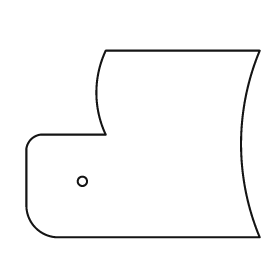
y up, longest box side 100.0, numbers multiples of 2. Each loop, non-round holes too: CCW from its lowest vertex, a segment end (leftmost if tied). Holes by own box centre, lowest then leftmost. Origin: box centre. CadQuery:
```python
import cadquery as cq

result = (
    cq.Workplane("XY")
    .moveTo(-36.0, -40.0)
    .lineTo(50.0, -40.0)
    .threePointArc((42.0, 0.0), (50.0, 40.0))
    .lineTo(-16.0, 40.0)
    .threePointArc((-20.0, 22.0), (-16.0, 4.0))
    .lineTo(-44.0, 4.0)
    .threePointArc((-48.0, 2.0), (-50.0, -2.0))
    .lineTo(-50.0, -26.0)
    .threePointArc((-46.0, -36.0), (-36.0, -40.0))
    .close()
    .moveTo(-26.0, -16.0)
    .circle(2.0)
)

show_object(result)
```